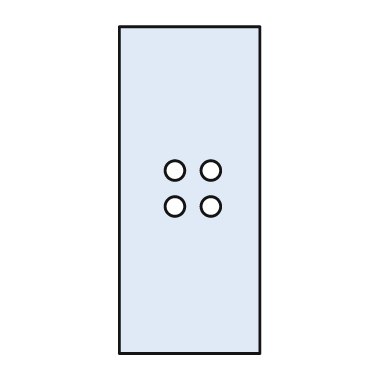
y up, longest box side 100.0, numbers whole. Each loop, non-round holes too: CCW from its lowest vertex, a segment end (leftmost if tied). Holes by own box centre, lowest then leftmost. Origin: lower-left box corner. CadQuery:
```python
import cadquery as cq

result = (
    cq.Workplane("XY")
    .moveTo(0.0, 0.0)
    .lineTo(43.0, 0.0)
    .lineTo(43.0, 100.0)
    .lineTo(0.0, 100.0)
    .close()
    .moveTo(17.0, 45.0)
    .circle(3.0)
    .moveTo(28.0, 45.0)
    .circle(3.0)
    .moveTo(17.0, 56.0)
    .circle(3.0)
    .moveTo(28.0, 56.0)
    .circle(3.0)
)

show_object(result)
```